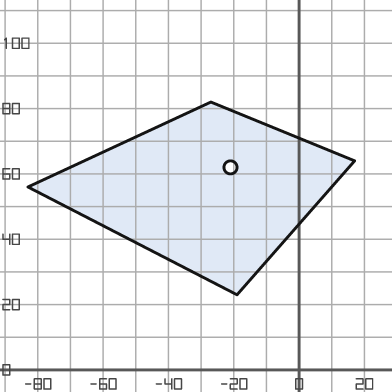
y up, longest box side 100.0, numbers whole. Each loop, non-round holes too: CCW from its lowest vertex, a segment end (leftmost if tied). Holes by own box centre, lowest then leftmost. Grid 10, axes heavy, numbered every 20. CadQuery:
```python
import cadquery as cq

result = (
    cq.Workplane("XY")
    .moveTo(-19.0, 23.0)
    .lineTo(17.0, 64.0)
    .lineTo(-27.0, 82.0)
    .lineTo(-83.0, 56.0)
    .close()
    .moveTo(-21.0, 62.0)
    .circle(2.0)
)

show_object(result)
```